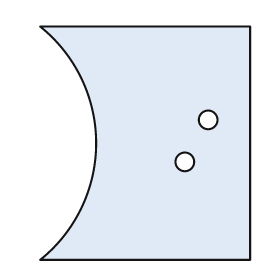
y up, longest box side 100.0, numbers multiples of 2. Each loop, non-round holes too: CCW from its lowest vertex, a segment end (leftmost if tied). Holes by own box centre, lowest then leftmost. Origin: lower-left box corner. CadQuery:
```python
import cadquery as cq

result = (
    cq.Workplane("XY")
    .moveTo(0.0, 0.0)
    .lineTo(90.0, 0.0)
    .lineTo(90.0, 100.0)
    .lineTo(0.0, 100.0)
    .threePointArc((24.0, 50.0), (0.0, 0.0))
    .close()
    .moveTo(62.0, 42.0)
    .circle(4.0)
    .moveTo(72.0, 60.0)
    .circle(4.0)
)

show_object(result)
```